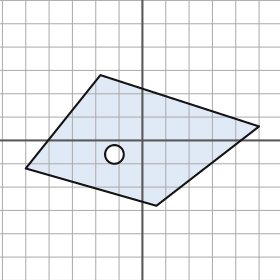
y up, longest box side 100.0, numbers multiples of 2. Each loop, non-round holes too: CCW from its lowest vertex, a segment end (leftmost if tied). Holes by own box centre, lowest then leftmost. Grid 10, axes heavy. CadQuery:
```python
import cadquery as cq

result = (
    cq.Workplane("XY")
    .moveTo(6.0, -28.0)
    .lineTo(50.0, 6.0)
    .lineTo(-18.0, 28.0)
    .lineTo(-50.0, -12.0)
    .close()
    .moveTo(-12.0, -6.0)
    .circle(4.0)
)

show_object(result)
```